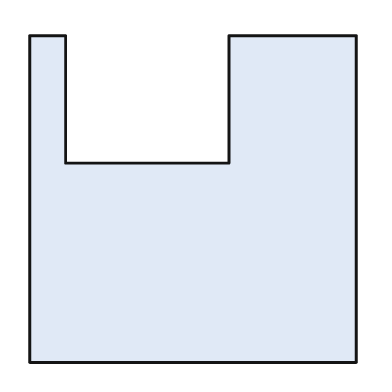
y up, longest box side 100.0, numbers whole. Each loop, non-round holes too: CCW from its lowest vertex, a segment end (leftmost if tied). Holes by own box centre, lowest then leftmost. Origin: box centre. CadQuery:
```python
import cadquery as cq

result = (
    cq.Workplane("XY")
    .moveTo(-50.0, -50.0)
    .lineTo(50.0, -50.0)
    .lineTo(50.0, 50.0)
    .lineTo(11.0, 50.0)
    .lineTo(11.0, 11.0)
    .lineTo(-39.0, 11.0)
    .lineTo(-39.0, 50.0)
    .lineTo(-50.0, 50.0)
    .close()
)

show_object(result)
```